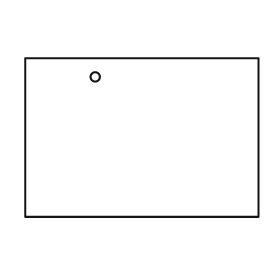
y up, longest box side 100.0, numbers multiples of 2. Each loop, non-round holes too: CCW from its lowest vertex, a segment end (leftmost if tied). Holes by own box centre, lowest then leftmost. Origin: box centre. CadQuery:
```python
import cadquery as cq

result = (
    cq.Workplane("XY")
    .moveTo(-50.0, -34.0)
    .lineTo(50.0, -34.0)
    .lineTo(50.0, 34.0)
    .lineTo(-50.0, 34.0)
    .close()
    .moveTo(-20.0, 26.0)
    .circle(2.0)
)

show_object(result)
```